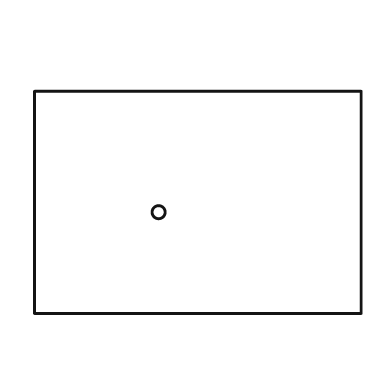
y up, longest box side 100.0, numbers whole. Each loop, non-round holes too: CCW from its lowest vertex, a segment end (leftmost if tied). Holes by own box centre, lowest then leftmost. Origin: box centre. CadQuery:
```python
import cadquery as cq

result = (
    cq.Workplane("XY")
    .moveTo(-50.0, -34.0)
    .lineTo(50.0, -34.0)
    .lineTo(50.0, 34.0)
    .lineTo(-50.0, 34.0)
    .close()
    .moveTo(-12.0, -3.0)
    .circle(2.0)
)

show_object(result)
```